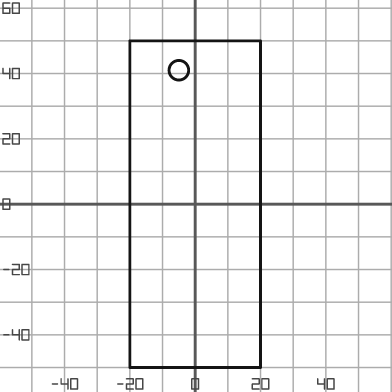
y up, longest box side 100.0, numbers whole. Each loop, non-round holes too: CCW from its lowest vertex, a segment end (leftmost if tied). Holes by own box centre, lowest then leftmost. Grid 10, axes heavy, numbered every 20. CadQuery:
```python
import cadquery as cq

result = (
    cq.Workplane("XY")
    .moveTo(-20.0, -50.0)
    .lineTo(20.0, -50.0)
    .lineTo(20.0, 50.0)
    .lineTo(-20.0, 50.0)
    .close()
    .moveTo(-5.0, 41.0)
    .circle(3.0)
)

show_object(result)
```